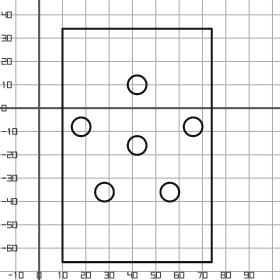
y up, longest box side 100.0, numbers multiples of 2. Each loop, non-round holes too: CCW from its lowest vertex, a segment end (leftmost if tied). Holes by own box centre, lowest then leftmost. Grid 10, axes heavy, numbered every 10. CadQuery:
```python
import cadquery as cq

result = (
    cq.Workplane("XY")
    .moveTo(10.0, -66.0)
    .lineTo(74.0, -66.0)
    .lineTo(74.0, 34.0)
    .lineTo(10.0, 34.0)
    .close()
    .moveTo(28.0, -36.0)
    .circle(4.0)
    .moveTo(56.0, -36.0)
    .circle(4.0)
    .moveTo(42.0, -16.0)
    .circle(4.0)
    .moveTo(18.0, -8.0)
    .circle(4.0)
    .moveTo(66.0, -8.0)
    .circle(4.0)
    .moveTo(42.0, 10.0)
    .circle(4.0)
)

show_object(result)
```